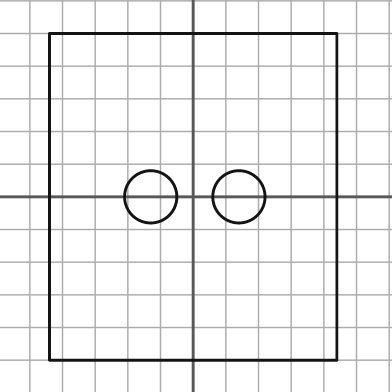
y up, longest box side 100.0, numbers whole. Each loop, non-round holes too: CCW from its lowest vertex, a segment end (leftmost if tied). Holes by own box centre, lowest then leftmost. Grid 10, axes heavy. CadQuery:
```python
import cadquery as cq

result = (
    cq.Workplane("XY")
    .moveTo(-44.0, -50.0)
    .lineTo(44.0, -50.0)
    .lineTo(44.0, 50.0)
    .lineTo(-44.0, 50.0)
    .close()
    .moveTo(-13.0, 0.0)
    .circle(8.0)
    .moveTo(14.0, 0.0)
    .circle(8.0)
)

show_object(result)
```